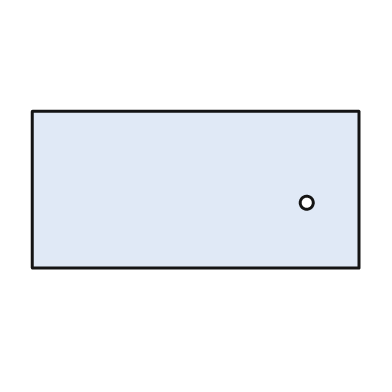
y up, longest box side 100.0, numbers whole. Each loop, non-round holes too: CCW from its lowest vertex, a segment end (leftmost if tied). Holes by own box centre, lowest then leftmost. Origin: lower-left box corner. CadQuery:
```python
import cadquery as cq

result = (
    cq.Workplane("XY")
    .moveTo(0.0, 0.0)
    .lineTo(100.0, 0.0)
    .lineTo(100.0, 48.0)
    .lineTo(0.0, 48.0)
    .close()
    .moveTo(84.0, 20.0)
    .circle(2.0)
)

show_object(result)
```